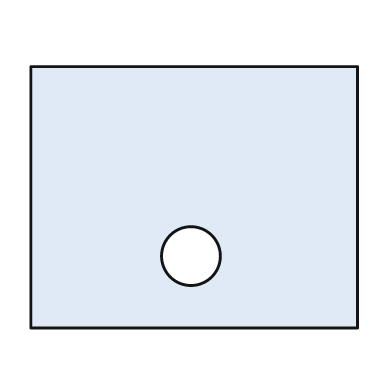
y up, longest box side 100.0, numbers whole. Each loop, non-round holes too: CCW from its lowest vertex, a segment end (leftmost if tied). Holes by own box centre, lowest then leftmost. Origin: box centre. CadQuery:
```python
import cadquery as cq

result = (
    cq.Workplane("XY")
    .moveTo(-50.0, -40.0)
    .lineTo(50.0, -40.0)
    .lineTo(50.0, 40.0)
    .lineTo(-50.0, 40.0)
    .close()
    .moveTo(-1.0, -18.0)
    .circle(9.0)
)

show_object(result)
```